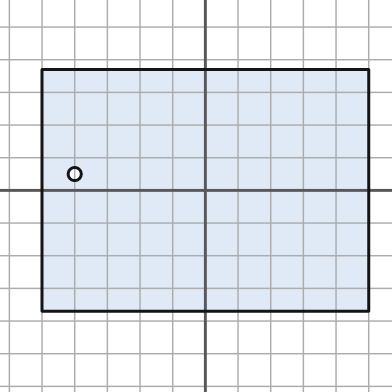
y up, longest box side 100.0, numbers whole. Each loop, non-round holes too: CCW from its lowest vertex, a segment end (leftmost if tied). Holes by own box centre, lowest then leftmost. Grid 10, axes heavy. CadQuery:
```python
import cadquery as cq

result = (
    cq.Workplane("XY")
    .moveTo(-50.0, -37.0)
    .lineTo(50.0, -37.0)
    .lineTo(50.0, 37.0)
    .lineTo(-50.0, 37.0)
    .close()
    .moveTo(-40.0, 5.0)
    .circle(2.0)
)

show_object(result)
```